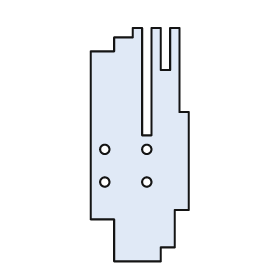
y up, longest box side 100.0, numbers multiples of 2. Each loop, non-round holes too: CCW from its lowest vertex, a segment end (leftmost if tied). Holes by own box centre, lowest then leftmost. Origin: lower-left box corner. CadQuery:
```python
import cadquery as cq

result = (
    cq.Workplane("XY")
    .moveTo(10.0, 0.0)
    .lineTo(30.0, 0.0)
    .lineTo(30.0, 6.0)
    .lineTo(36.0, 6.0)
    .lineTo(36.0, 22.0)
    .lineTo(42.0, 22.0)
    .lineTo(42.0, 64.0)
    .lineTo(38.0, 64.0)
    .lineTo(38.0, 100.0)
    .lineTo(34.0, 100.0)
    .lineTo(34.0, 82.0)
    .lineTo(30.0, 82.0)
    .lineTo(30.0, 100.0)
    .lineTo(26.0, 100.0)
    .lineTo(26.0, 54.0)
    .lineTo(22.0, 54.0)
    .lineTo(22.0, 100.0)
    .lineTo(18.0, 100.0)
    .lineTo(18.0, 96.0)
    .lineTo(10.0, 96.0)
    .lineTo(10.0, 90.0)
    .lineTo(0.0, 90.0)
    .lineTo(0.0, 18.0)
    .lineTo(10.0, 18.0)
    .close()
    .moveTo(6.0, 34.0)
    .circle(2.0)
    .moveTo(24.0, 34.0)
    .circle(2.0)
    .moveTo(6.0, 48.0)
    .circle(2.0)
    .moveTo(24.0, 48.0)
    .circle(2.0)
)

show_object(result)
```